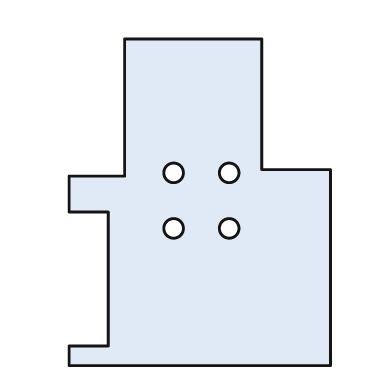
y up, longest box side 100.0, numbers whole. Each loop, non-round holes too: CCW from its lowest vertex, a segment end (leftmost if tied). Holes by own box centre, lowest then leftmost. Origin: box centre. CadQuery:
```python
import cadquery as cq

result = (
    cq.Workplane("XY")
    .moveTo(-40.0, -50.0)
    .lineTo(40.0, -50.0)
    .lineTo(40.0, 10.0)
    .lineTo(19.0, 10.0)
    .lineTo(19.0, 50.0)
    .lineTo(-23.0, 50.0)
    .lineTo(-23.0, 8.0)
    .lineTo(-40.0, 8.0)
    .lineTo(-40.0, -3.0)
    .lineTo(-28.0, -3.0)
    .lineTo(-28.0, -44.0)
    .lineTo(-40.0, -44.0)
    .close()
    .moveTo(-8.0, -8.0)
    .circle(3.0)
    .moveTo(9.0, -8.0)
    .circle(3.0)
    .moveTo(-8.0, 9.0)
    .circle(3.0)
    .moveTo(9.0, 9.0)
    .circle(3.0)
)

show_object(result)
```